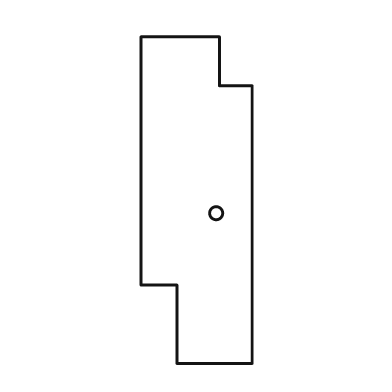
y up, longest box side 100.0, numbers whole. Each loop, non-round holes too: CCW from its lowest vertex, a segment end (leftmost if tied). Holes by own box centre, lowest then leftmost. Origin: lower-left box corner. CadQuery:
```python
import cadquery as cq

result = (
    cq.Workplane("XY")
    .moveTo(11.0, 0.0)
    .lineTo(34.0, 0.0)
    .lineTo(34.0, 85.0)
    .lineTo(24.0, 85.0)
    .lineTo(24.0, 100.0)
    .lineTo(0.0, 100.0)
    .lineTo(0.0, 24.0)
    .lineTo(11.0, 24.0)
    .close()
    .moveTo(23.0, 46.0)
    .circle(2.0)
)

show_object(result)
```